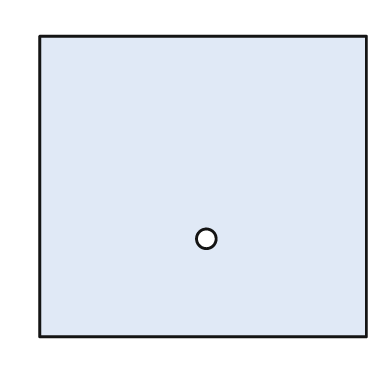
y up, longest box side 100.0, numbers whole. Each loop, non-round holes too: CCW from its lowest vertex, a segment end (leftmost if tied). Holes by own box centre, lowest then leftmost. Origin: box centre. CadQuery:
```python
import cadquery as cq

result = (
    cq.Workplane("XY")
    .moveTo(-50.0, -46.0)
    .lineTo(50.0, -46.0)
    .lineTo(50.0, 46.0)
    .lineTo(-50.0, 46.0)
    .close()
    .moveTo(1.0, -16.0)
    .circle(3.0)
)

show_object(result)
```